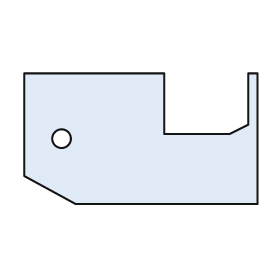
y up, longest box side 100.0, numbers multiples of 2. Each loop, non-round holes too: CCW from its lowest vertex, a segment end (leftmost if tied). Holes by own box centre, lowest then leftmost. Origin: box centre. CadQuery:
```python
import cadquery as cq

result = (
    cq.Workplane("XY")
    .moveTo(-28.0, -28.0)
    .lineTo(50.0, -28.0)
    .lineTo(50.0, 28.0)
    .lineTo(46.0, 28.0)
    .lineTo(46.0, 6.0)
    .lineTo(38.0, 2.0)
    .lineTo(10.0, 2.0)
    .lineTo(10.0, 28.0)
    .lineTo(-50.0, 28.0)
    .lineTo(-50.0, -16.0)
    .close()
    .moveTo(-34.0, 0.0)
    .circle(4.0)
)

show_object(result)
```